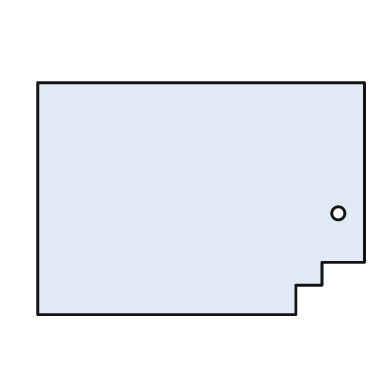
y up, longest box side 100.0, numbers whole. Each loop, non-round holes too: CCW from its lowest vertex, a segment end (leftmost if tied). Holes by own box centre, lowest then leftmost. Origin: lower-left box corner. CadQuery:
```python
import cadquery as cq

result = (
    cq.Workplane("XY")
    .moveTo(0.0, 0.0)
    .lineTo(79.0, 0.0)
    .lineTo(79.0, 9.0)
    .lineTo(87.0, 9.0)
    .lineTo(87.0, 16.0)
    .lineTo(100.0, 16.0)
    .lineTo(100.0, 71.0)
    .lineTo(0.0, 71.0)
    .close()
    .moveTo(92.0, 31.0)
    .circle(2.0)
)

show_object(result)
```